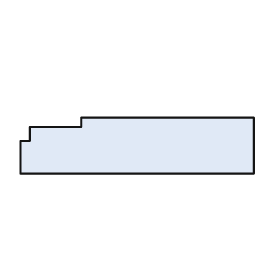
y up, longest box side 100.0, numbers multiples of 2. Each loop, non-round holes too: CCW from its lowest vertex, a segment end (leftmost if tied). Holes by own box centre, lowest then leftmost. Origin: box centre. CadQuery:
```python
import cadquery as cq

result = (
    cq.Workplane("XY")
    .moveTo(-50.0, -12.0)
    .lineTo(50.0, -12.0)
    .lineTo(50.0, 12.0)
    .lineTo(-24.0, 12.0)
    .lineTo(-24.0, 8.0)
    .lineTo(-46.0, 8.0)
    .lineTo(-46.0, 2.0)
    .lineTo(-50.0, 2.0)
    .close()
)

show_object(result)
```